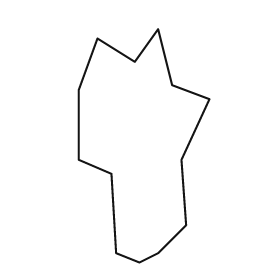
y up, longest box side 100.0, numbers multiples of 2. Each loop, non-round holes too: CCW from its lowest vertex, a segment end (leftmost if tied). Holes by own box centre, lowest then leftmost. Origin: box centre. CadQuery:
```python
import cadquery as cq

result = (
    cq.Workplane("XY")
    .moveTo(-2.0, -50.0)
    .lineTo(6.0, -46.0)
    .lineTo(18.0, -34.0)
    .lineTo(16.0, -6.0)
    .lineTo(28.0, 20.0)
    .lineTo(12.0, 26.0)
    .lineTo(6.0, 50.0)
    .lineTo(-4.0, 36.0)
    .lineTo(-20.0, 46.0)
    .lineTo(-28.0, 24.0)
    .lineTo(-28.0, -6.0)
    .lineTo(-14.0, -12.0)
    .lineTo(-12.0, -46.0)
    .close()
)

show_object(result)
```